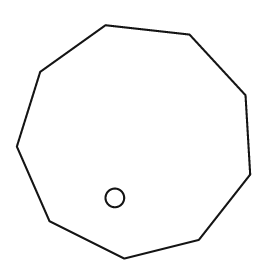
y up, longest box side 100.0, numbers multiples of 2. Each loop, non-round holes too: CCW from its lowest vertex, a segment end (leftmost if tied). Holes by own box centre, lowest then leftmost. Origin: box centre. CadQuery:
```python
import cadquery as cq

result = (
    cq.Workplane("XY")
    .moveTo(-4.0, -50.0)
    .lineTo(28.0, -42.0)
    .lineTo(50.0, -14.0)
    .lineTo(48.0, 20.0)
    .lineTo(24.0, 46.0)
    .lineTo(-12.0, 50.0)
    .lineTo(-40.0, 30.0)
    .lineTo(-50.0, -2.0)
    .lineTo(-36.0, -34.0)
    .close()
    .moveTo(-8.0, -24.0)
    .circle(4.0)
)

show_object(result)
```